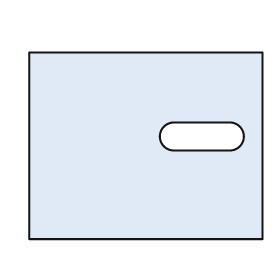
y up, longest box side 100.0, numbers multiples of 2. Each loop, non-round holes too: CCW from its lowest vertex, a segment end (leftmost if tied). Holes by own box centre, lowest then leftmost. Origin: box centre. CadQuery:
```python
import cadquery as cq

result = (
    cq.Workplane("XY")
    .moveTo(-50.0, -40.0)
    .lineTo(50.0, -40.0)
    .lineTo(50.0, 40.0)
    .lineTo(-50.0, 40.0)
    .close()
    .moveTo(12.0, -2.0)
    .lineTo(36.0, -2.0)
    .threePointArc((42.0, 4.0), (36.0, 10.0))
    .lineTo(12.0, 10.0)
    .threePointArc((6.0, 4.0), (12.0, -2.0))
    .close()
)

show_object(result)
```